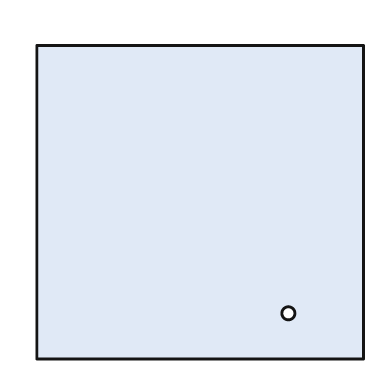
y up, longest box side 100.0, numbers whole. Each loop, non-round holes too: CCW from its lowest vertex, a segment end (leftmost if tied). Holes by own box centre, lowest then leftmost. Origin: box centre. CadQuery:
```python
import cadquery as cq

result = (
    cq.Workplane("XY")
    .moveTo(-50.0, -48.0)
    .lineTo(50.0, -48.0)
    .lineTo(50.0, 48.0)
    .lineTo(-50.0, 48.0)
    .close()
    .moveTo(27.0, -34.0)
    .circle(2.0)
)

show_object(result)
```